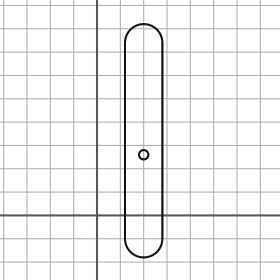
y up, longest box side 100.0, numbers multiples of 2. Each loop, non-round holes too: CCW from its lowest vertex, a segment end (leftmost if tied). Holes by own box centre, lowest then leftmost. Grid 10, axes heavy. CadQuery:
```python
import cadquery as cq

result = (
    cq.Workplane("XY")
    .moveTo(12.0, -10.0)
    .threePointArc((20.0, -18.0), (28.0, -10.0))
    .lineTo(28.0, 74.0)
    .threePointArc((20.0, 82.0), (12.0, 74.0))
    .close()
    .moveTo(20.0, 26.0)
    .circle(2.0)
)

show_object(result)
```